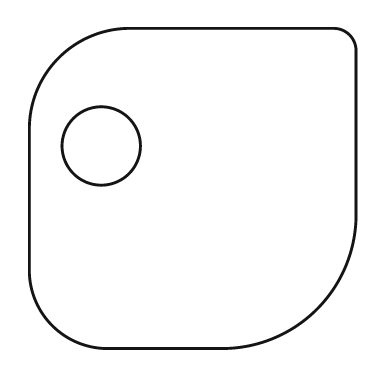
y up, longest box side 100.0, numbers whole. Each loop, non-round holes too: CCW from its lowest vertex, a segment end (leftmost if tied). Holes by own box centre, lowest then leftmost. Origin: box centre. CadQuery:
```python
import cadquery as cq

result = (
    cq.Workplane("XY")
    .moveTo(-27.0, -49.0)
    .lineTo(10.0, -49.0)
    .threePointArc((38.0, -37.0), (50.0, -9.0))
    .lineTo(50.0, 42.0)
    .threePointArc((48.0, 47.0), (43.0, 49.0))
    .lineTo(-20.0, 49.0)
    .threePointArc((-41.0, 40.0), (-50.0, 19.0))
    .lineTo(-50.0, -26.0)
    .threePointArc((-43.0, -42.0), (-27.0, -49.0))
    .close()
    .moveTo(-28.0, 13.0)
    .circle(12.0)
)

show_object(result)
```